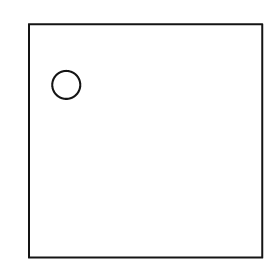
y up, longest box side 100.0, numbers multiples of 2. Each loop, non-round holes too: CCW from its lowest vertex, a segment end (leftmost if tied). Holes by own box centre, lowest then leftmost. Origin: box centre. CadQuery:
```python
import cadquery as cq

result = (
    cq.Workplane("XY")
    .moveTo(-50.0, -50.0)
    .lineTo(50.0, -50.0)
    .lineTo(50.0, 50.0)
    .lineTo(-50.0, 50.0)
    .close()
    .moveTo(-34.0, 24.0)
    .circle(6.0)
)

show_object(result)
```